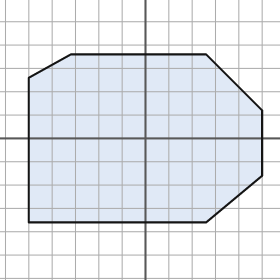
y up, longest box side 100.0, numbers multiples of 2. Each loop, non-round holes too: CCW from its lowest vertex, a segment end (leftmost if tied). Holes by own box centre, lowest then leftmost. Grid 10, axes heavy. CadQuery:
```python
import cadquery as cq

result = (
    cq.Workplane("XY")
    .moveTo(-50.0, -36.0)
    .lineTo(26.0, -36.0)
    .lineTo(50.0, -16.0)
    .lineTo(50.0, 12.0)
    .lineTo(26.0, 36.0)
    .lineTo(-32.0, 36.0)
    .lineTo(-50.0, 26.0)
    .close()
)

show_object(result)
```